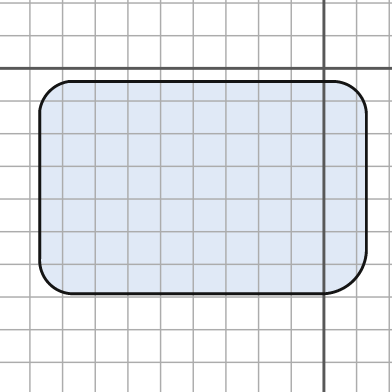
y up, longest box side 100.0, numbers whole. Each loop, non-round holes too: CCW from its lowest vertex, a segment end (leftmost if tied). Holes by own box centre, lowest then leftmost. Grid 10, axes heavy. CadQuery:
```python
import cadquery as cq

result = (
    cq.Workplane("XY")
    .moveTo(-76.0, -69.0)
    .lineTo(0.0, -69.0)
    .threePointArc((9.0, -65.0), (13.0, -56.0))
    .lineTo(13.0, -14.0)
    .threePointArc((10.0, -7.0), (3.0, -4.0))
    .lineTo(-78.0, -4.0)
    .threePointArc((-84.0, -7.0), (-87.0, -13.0))
    .lineTo(-87.0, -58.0)
    .threePointArc((-84.0, -66.0), (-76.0, -69.0))
    .close()
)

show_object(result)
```